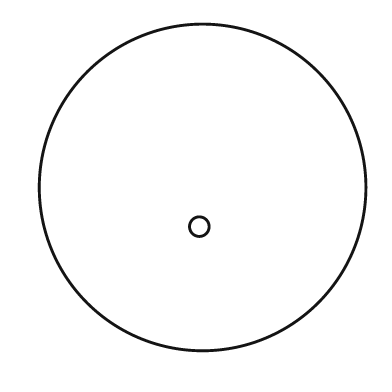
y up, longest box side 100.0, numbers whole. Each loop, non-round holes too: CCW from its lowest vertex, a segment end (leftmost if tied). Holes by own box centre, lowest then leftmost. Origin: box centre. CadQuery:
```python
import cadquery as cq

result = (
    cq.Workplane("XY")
    .moveTo(0.0, 0.0)
    .circle(50.0)
    .moveTo(-1.0, -12.0)
    .circle(3.0)
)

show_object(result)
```